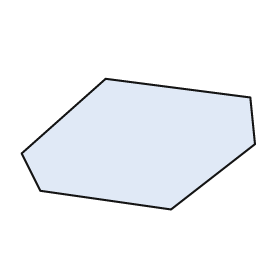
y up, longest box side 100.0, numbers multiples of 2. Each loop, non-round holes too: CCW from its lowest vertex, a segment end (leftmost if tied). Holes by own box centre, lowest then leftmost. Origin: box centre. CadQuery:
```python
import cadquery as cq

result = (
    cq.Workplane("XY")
    .moveTo(14.0, -28.0)
    .lineTo(50.0, 0.0)
    .lineTo(48.0, 20.0)
    .lineTo(-14.0, 28.0)
    .lineTo(-50.0, -4.0)
    .lineTo(-42.0, -20.0)
    .close()
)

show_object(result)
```